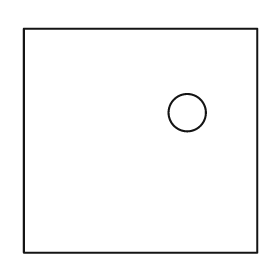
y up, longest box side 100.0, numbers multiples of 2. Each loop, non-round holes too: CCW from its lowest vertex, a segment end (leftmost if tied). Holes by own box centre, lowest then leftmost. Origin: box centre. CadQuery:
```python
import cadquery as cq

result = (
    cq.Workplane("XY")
    .moveTo(-50.0, -48.0)
    .lineTo(50.0, -48.0)
    .lineTo(50.0, 48.0)
    .lineTo(-50.0, 48.0)
    .close()
    .moveTo(20.0, 12.0)
    .circle(8.0)
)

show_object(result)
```